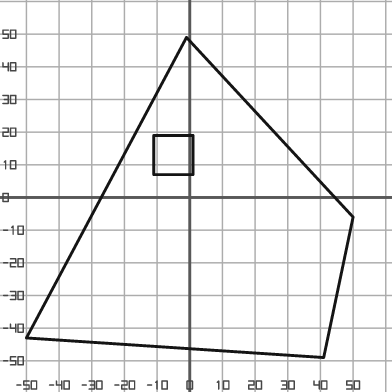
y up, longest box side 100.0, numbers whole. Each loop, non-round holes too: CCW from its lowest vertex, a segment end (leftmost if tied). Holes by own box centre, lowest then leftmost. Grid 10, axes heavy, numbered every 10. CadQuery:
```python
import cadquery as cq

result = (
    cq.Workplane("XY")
    .moveTo(41.0, -49.0)
    .lineTo(50.0, -6.0)
    .lineTo(-1.0, 49.0)
    .lineTo(-50.0, -43.0)
    .close()
    .moveTo(-11.0, 7.0)
    .lineTo(1.0, 7.0)
    .lineTo(1.0, 19.0)
    .lineTo(-11.0, 19.0)
    .close()
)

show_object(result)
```